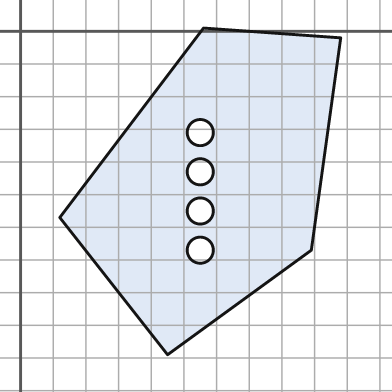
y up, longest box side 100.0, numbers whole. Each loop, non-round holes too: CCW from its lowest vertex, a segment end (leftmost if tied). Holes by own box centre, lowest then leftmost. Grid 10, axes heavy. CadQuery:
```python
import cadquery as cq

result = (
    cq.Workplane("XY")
    .moveTo(45.0, -99.0)
    .lineTo(89.0, -67.0)
    .lineTo(98.0, -2.0)
    .lineTo(56.0, 1.0)
    .lineTo(12.0, -57.0)
    .close()
    .moveTo(55.0, -67.0)
    .circle(4.0)
    .moveTo(55.0, -55.0)
    .circle(4.0)
    .moveTo(55.0, -43.0)
    .circle(4.0)
    .moveTo(55.0, -31.0)
    .circle(4.0)
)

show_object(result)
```